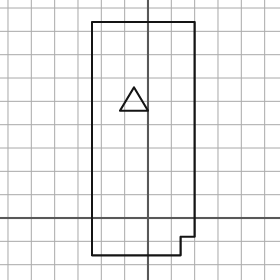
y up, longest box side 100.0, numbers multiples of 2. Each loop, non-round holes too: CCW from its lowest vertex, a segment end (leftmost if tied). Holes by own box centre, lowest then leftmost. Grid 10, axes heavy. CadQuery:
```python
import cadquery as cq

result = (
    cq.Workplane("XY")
    .moveTo(-24.0, -16.0)
    .lineTo(14.0, -16.0)
    .lineTo(14.0, -8.0)
    .lineTo(20.0, -8.0)
    .lineTo(20.0, 84.0)
    .lineTo(-24.0, 84.0)
    .close()
    .moveTo(-12.0, 46.0)
    .lineTo(0.0, 46.0)
    .lineTo(-6.0, 56.0)
    .close()
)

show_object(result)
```